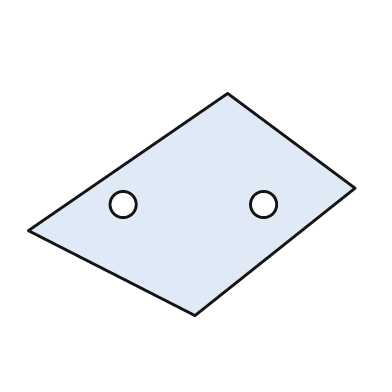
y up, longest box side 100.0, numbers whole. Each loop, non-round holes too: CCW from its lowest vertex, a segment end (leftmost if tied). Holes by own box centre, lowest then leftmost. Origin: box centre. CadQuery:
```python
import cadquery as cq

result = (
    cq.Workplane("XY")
    .moveTo(1.0, -34.0)
    .lineTo(50.0, 5.0)
    .lineTo(11.0, 34.0)
    .lineTo(-50.0, -8.0)
    .close()
    .moveTo(-21.0, 0.0)
    .circle(4.0)
    .moveTo(22.0, 0.0)
    .circle(4.0)
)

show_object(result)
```